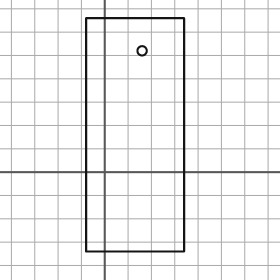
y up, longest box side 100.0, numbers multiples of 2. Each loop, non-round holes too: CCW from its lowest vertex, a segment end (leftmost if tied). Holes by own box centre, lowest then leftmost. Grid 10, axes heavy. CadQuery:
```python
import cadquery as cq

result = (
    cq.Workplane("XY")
    .moveTo(-8.0, -34.0)
    .lineTo(34.0, -34.0)
    .lineTo(34.0, 66.0)
    .lineTo(-8.0, 66.0)
    .close()
    .moveTo(16.0, 52.0)
    .circle(2.0)
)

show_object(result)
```